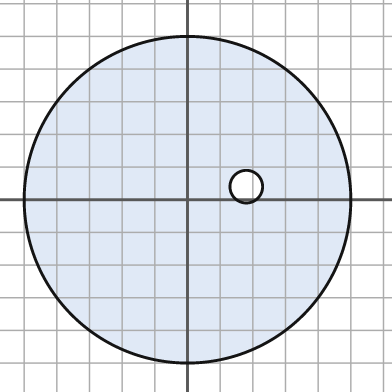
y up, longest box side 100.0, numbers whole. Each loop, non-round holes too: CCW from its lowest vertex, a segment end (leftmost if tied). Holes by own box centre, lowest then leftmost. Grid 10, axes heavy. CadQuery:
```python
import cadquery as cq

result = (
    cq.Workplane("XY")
    .moveTo(0.0, 0.0)
    .circle(50.0)
    .moveTo(18.0, 4.0)
    .circle(5.0)
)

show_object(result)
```